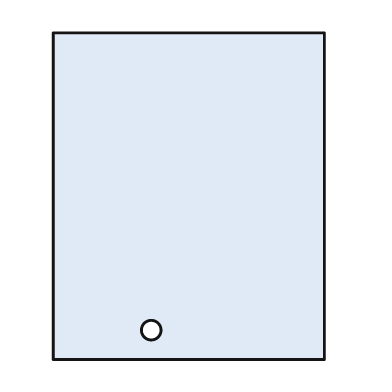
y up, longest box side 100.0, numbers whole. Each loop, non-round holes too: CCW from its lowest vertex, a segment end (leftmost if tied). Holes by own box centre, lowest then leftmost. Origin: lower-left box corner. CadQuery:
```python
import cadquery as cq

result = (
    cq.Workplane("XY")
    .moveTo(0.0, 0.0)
    .lineTo(83.0, 0.0)
    .lineTo(83.0, 100.0)
    .lineTo(0.0, 100.0)
    .close()
    .moveTo(30.0, 9.0)
    .circle(3.0)
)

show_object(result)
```